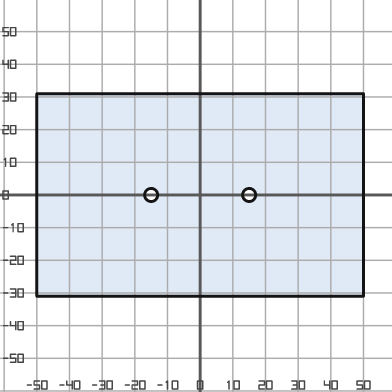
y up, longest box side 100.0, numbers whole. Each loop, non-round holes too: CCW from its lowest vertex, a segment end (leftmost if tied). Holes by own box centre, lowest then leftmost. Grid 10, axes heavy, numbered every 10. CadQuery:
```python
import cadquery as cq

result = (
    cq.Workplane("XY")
    .moveTo(-50.0, -31.0)
    .lineTo(50.0, -31.0)
    .lineTo(50.0, 31.0)
    .lineTo(-50.0, 31.0)
    .close()
    .moveTo(-15.0, 0.0)
    .circle(2.0)
    .moveTo(15.0, 0.0)
    .circle(2.0)
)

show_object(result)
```